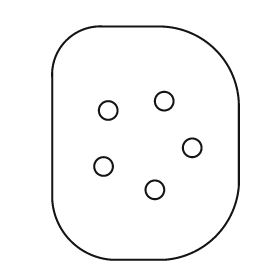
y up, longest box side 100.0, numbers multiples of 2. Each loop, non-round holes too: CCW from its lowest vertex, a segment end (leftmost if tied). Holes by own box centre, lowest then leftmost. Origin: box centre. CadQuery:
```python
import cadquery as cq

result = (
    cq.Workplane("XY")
    .moveTo(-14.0, -50.0)
    .lineTo(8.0, -50.0)
    .threePointArc((30.0, -40.0), (40.0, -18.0))
    .lineTo(40.0, 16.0)
    .threePointArc((30.0, 40.0), (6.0, 50.0))
    .lineTo(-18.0, 50.0)
    .threePointArc((-34.0, 44.0), (-40.0, 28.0))
    .lineTo(-40.0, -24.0)
    .threePointArc((-32.0, -42.0), (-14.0, -50.0))
    .close()
    .moveTo(4.0, -20.0)
    .circle(4.0)
    .moveTo(-18.0, -10.0)
    .circle(4.0)
    .moveTo(20.0, -2.0)
    .circle(4.0)
    .moveTo(-16.0, 14.0)
    .circle(4.0)
    .moveTo(8.0, 18.0)
    .circle(4.0)
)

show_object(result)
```